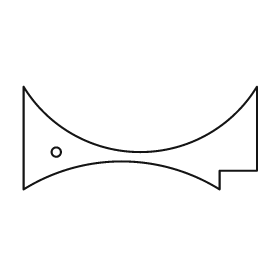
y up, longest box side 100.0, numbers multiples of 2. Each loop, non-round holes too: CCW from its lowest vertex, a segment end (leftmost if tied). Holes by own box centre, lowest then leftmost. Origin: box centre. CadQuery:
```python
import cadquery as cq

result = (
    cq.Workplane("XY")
    .moveTo(-50.0, -22.0)
    .threePointArc((-8.0, -10.0), (34.0, -22.0))
    .lineTo(34.0, -14.0)
    .lineTo(50.0, -14.0)
    .lineTo(50.0, 22.0)
    .threePointArc((0.0, -6.0), (-50.0, 22.0))
    .close()
    .moveTo(-36.0, -6.0)
    .circle(2.0)
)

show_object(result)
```